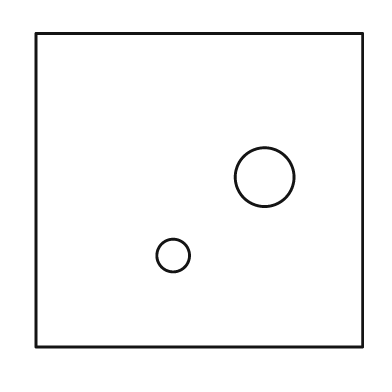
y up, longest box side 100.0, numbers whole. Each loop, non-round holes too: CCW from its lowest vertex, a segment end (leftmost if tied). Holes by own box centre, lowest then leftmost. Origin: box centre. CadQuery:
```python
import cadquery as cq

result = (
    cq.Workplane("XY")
    .moveTo(-50.0, -48.0)
    .lineTo(50.0, -48.0)
    .lineTo(50.0, 48.0)
    .lineTo(-50.0, 48.0)
    .close()
    .moveTo(-8.0, -20.0)
    .circle(5.0)
    .moveTo(20.0, 4.0)
    .circle(9.0)
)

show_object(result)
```